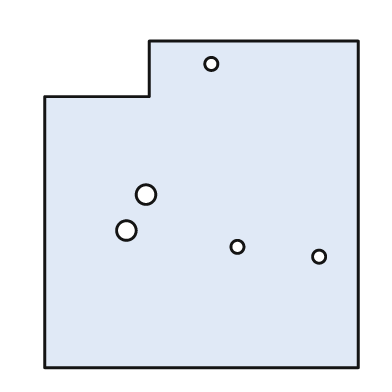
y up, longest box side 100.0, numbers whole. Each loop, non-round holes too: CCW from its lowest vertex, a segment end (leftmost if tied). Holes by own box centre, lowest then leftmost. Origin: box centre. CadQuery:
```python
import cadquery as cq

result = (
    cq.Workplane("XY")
    .moveTo(-48.0, -50.0)
    .lineTo(48.0, -50.0)
    .lineTo(48.0, 50.0)
    .lineTo(-16.0, 50.0)
    .lineTo(-16.0, 33.0)
    .lineTo(-48.0, 33.0)
    .close()
    .moveTo(36.0, -16.0)
    .circle(2.0)
    .moveTo(11.0, -13.0)
    .circle(2.0)
    .moveTo(-23.0, -8.0)
    .circle(3.0)
    .moveTo(-17.0, 3.0)
    .circle(3.0)
    .moveTo(3.0, 43.0)
    .circle(2.0)
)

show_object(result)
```